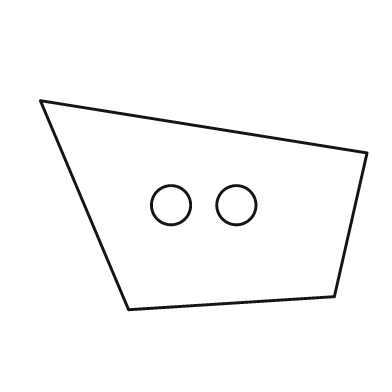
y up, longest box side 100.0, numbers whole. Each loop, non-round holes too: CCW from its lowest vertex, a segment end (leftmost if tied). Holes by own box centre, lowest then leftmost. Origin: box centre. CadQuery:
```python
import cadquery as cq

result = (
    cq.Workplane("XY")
    .moveTo(-23.0, -32.0)
    .lineTo(40.0, -28.0)
    .lineTo(50.0, 16.0)
    .lineTo(-50.0, 32.0)
    .close()
    .moveTo(-10.0, 0.0)
    .circle(6.0)
    .moveTo(10.0, 0.0)
    .circle(6.0)
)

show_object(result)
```